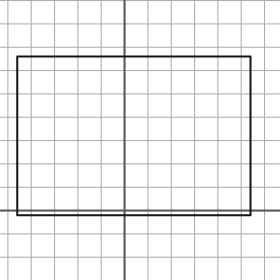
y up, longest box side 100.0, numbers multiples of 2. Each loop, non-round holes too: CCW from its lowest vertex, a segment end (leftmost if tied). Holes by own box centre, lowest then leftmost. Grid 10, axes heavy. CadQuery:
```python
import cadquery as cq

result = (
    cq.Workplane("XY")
    .moveTo(-46.0, -2.0)
    .lineTo(54.0, -2.0)
    .lineTo(54.0, 66.0)
    .lineTo(-46.0, 66.0)
    .close()
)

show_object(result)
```